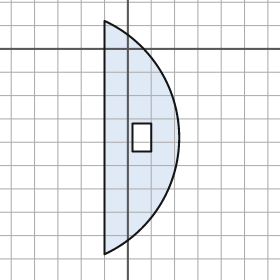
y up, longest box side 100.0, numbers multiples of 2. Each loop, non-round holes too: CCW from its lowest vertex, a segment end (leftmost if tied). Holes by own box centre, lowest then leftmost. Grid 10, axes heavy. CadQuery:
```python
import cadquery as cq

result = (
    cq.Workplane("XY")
    .moveTo(-10.0, -88.0)
    .threePointArc((22.0, -38.0), (-10.0, 12.0))
    .close()
    .moveTo(2.0, -44.0)
    .lineTo(10.0, -44.0)
    .lineTo(10.0, -32.0)
    .lineTo(2.0, -32.0)
    .close()
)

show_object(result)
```